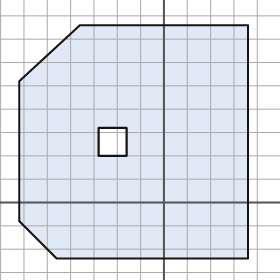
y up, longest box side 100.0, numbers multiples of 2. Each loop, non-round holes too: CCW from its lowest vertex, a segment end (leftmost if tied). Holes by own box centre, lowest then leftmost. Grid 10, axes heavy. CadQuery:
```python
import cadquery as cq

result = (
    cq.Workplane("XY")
    .moveTo(-46.0, -24.0)
    .lineTo(36.0, -24.0)
    .lineTo(36.0, 76.0)
    .lineTo(-36.0, 76.0)
    .lineTo(-62.0, 52.0)
    .lineTo(-62.0, -8.0)
    .close()
    .moveTo(-28.0, 20.0)
    .lineTo(-16.0, 20.0)
    .lineTo(-16.0, 32.0)
    .lineTo(-28.0, 32.0)
    .close()
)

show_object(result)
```